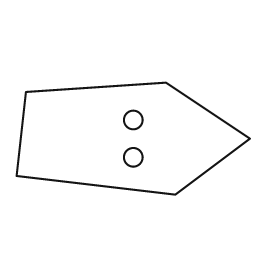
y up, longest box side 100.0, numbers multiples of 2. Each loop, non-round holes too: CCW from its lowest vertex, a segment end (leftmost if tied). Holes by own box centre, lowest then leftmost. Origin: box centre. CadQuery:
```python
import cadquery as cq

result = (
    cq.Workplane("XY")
    .moveTo(18.0, -24.0)
    .lineTo(50.0, 0.0)
    .lineTo(14.0, 24.0)
    .lineTo(-46.0, 20.0)
    .lineTo(-50.0, -16.0)
    .close()
    .moveTo(0.0, -8.0)
    .circle(4.0)
    .moveTo(0.0, 8.0)
    .circle(4.0)
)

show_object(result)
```